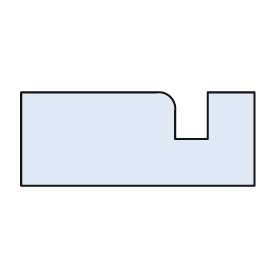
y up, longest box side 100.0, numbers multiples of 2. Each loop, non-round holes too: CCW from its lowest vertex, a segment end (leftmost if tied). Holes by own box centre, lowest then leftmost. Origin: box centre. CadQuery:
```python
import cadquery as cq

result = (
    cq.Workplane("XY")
    .moveTo(-50.0, -20.0)
    .lineTo(50.0, -20.0)
    .lineTo(50.0, 20.0)
    .lineTo(30.0, 20.0)
    .lineTo(30.0, 0.0)
    .lineTo(16.0, 0.0)
    .lineTo(16.0, 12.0)
    .threePointArc((14.0, 18.0), (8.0, 20.0))
    .lineTo(-50.0, 20.0)
    .close()
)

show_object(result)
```